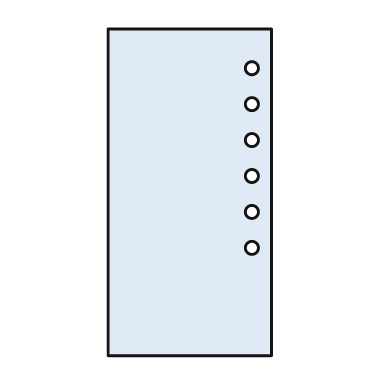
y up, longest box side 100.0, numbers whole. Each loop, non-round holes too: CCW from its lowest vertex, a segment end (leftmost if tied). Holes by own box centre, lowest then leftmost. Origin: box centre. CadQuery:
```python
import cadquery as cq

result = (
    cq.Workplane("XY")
    .moveTo(-25.0, -50.0)
    .lineTo(25.0, -50.0)
    .lineTo(25.0, 50.0)
    .lineTo(-25.0, 50.0)
    .close()
    .moveTo(19.0, -17.0)
    .circle(2.0)
    .moveTo(19.0, -6.0)
    .circle(2.0)
    .moveTo(19.0, 5.0)
    .circle(2.0)
    .moveTo(19.0, 16.0)
    .circle(2.0)
    .moveTo(19.0, 27.0)
    .circle(2.0)
    .moveTo(19.0, 38.0)
    .circle(2.0)
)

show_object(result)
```